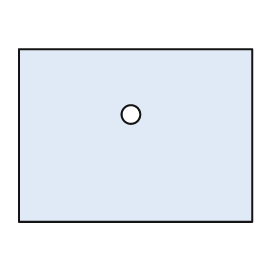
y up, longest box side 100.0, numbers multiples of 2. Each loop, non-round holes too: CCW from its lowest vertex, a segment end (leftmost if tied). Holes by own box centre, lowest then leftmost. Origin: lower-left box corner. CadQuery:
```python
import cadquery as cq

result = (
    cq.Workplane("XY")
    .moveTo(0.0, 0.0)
    .lineTo(100.0, 0.0)
    .lineTo(100.0, 74.0)
    .lineTo(0.0, 74.0)
    .close()
    .moveTo(48.0, 46.0)
    .circle(4.0)
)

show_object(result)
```